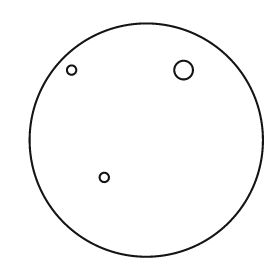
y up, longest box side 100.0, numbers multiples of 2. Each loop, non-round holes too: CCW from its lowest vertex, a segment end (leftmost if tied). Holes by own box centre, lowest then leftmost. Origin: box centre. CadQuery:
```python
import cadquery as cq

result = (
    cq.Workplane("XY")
    .moveTo(0.0, 0.0)
    .circle(50.0)
    .moveTo(-18.0, -16.0)
    .circle(2.0)
    .moveTo(-32.0, 30.0)
    .circle(2.0)
    .moveTo(16.0, 30.0)
    .circle(4.0)
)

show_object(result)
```